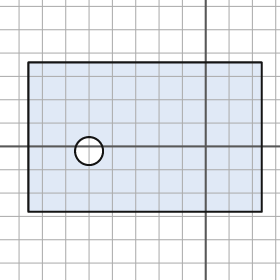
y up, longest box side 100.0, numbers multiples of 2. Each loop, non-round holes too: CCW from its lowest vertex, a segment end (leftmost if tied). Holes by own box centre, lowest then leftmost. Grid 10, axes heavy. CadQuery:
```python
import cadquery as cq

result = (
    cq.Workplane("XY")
    .moveTo(-76.0, -28.0)
    .lineTo(24.0, -28.0)
    .lineTo(24.0, 36.0)
    .lineTo(-76.0, 36.0)
    .close()
    .moveTo(-50.0, -2.0)
    .circle(6.0)
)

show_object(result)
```